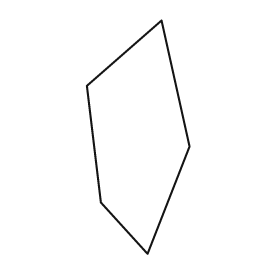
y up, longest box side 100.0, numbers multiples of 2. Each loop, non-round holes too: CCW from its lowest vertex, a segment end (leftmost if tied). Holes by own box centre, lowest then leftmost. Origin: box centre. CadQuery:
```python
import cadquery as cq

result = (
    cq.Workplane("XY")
    .moveTo(4.0, -50.0)
    .lineTo(22.0, -4.0)
    .lineTo(10.0, 50.0)
    .lineTo(-22.0, 22.0)
    .lineTo(-16.0, -28.0)
    .close()
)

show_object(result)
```